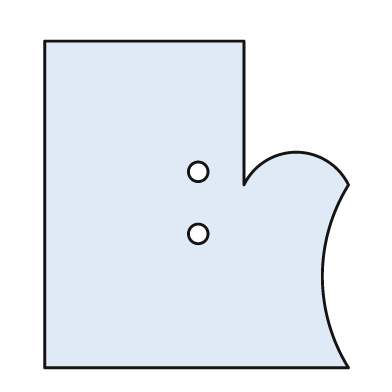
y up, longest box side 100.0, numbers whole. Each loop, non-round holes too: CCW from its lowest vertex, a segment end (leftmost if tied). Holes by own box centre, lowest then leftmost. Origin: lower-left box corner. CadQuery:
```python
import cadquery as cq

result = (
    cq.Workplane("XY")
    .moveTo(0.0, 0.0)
    .lineTo(93.0, 0.0)
    .threePointArc((85.0, 28.0), (93.0, 56.0))
    .threePointArc((77.0, 66.0), (61.0, 56.0))
    .lineTo(61.0, 100.0)
    .lineTo(0.0, 100.0)
    .close()
    .moveTo(47.0, 41.0)
    .circle(3.0)
    .moveTo(47.0, 60.0)
    .circle(3.0)
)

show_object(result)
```